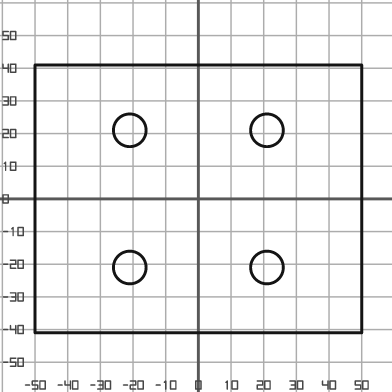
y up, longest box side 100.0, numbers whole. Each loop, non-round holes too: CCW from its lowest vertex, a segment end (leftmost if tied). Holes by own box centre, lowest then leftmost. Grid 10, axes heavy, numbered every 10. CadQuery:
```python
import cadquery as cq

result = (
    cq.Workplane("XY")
    .moveTo(-50.0, -41.0)
    .lineTo(50.0, -41.0)
    .lineTo(50.0, 41.0)
    .lineTo(-50.0, 41.0)
    .close()
    .moveTo(-21.0, -21.0)
    .circle(5.0)
    .moveTo(21.0, -21.0)
    .circle(5.0)
    .moveTo(-21.0, 21.0)
    .circle(5.0)
    .moveTo(21.0, 21.0)
    .circle(5.0)
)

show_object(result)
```